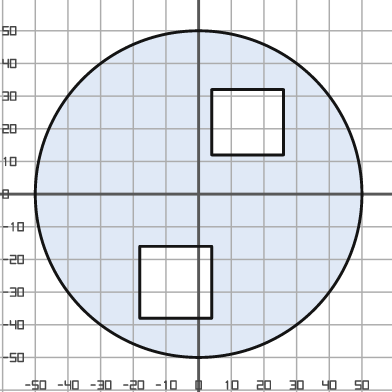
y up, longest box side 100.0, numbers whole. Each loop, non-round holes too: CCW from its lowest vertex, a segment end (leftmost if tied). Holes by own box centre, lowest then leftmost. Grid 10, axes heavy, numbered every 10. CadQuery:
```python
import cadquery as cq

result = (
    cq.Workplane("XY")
    .moveTo(0.0, 0.0)
    .circle(50.0)
    .moveTo(-18.0, -38.0)
    .lineTo(4.0, -38.0)
    .lineTo(4.0, -16.0)
    .lineTo(-18.0, -16.0)
    .close()
    .moveTo(4.0, 12.0)
    .lineTo(26.0, 12.0)
    .lineTo(26.0, 32.0)
    .lineTo(4.0, 32.0)
    .close()
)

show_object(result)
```